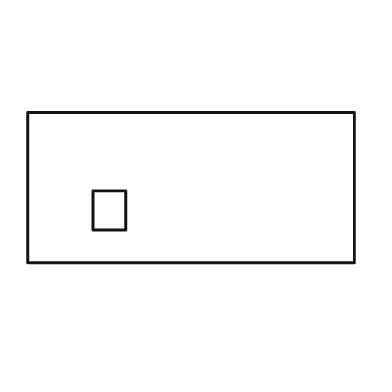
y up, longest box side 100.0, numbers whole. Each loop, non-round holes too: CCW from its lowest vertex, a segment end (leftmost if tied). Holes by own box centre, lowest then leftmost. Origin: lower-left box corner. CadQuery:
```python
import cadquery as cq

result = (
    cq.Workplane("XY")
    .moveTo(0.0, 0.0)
    .lineTo(100.0, 0.0)
    .lineTo(100.0, 46.0)
    .lineTo(0.0, 46.0)
    .close()
    .moveTo(20.0, 10.0)
    .lineTo(30.0, 10.0)
    .lineTo(30.0, 22.0)
    .lineTo(20.0, 22.0)
    .close()
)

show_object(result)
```